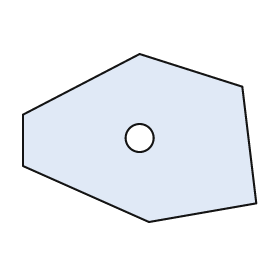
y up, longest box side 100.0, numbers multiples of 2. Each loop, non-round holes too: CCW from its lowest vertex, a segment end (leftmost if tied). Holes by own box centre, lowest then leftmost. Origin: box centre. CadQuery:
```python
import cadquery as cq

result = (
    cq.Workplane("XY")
    .moveTo(4.0, -36.0)
    .lineTo(50.0, -28.0)
    .lineTo(44.0, 22.0)
    .lineTo(0.0, 36.0)
    .lineTo(-50.0, 10.0)
    .lineTo(-50.0, -12.0)
    .close()
    .moveTo(0.0, 0.0)
    .circle(6.0)
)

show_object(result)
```